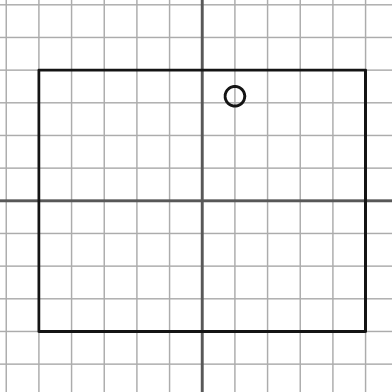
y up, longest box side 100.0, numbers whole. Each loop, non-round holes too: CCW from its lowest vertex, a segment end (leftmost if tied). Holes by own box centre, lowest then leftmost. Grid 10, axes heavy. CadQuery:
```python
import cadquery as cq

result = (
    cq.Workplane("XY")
    .moveTo(-50.0, -40.0)
    .lineTo(50.0, -40.0)
    .lineTo(50.0, 40.0)
    .lineTo(-50.0, 40.0)
    .close()
    .moveTo(10.0, 32.0)
    .circle(3.0)
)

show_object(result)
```